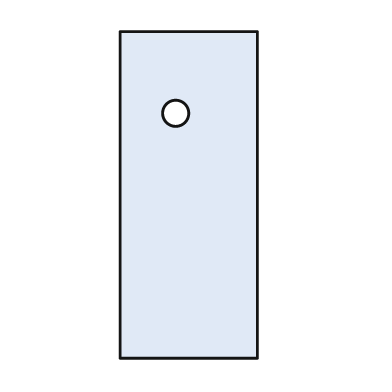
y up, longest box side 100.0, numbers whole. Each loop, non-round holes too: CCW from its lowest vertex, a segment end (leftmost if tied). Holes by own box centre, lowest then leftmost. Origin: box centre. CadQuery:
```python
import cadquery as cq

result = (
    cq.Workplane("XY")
    .moveTo(-21.0, -50.0)
    .lineTo(21.0, -50.0)
    .lineTo(21.0, 50.0)
    .lineTo(-21.0, 50.0)
    .close()
    .moveTo(-4.0, 25.0)
    .circle(4.0)
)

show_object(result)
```